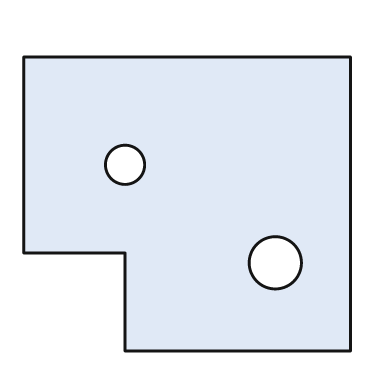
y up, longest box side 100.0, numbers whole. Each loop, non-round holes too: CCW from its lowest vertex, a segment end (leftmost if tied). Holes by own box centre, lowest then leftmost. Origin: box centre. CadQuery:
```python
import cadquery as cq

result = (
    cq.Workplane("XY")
    .moveTo(-19.0, -45.0)
    .lineTo(50.0, -45.0)
    .lineTo(50.0, 45.0)
    .lineTo(-50.0, 45.0)
    .lineTo(-50.0, -15.0)
    .lineTo(-19.0, -15.0)
    .close()
    .moveTo(27.0, -18.0)
    .circle(8.0)
    .moveTo(-19.0, 12.0)
    .circle(6.0)
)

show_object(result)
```